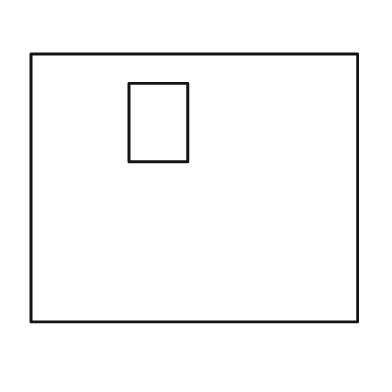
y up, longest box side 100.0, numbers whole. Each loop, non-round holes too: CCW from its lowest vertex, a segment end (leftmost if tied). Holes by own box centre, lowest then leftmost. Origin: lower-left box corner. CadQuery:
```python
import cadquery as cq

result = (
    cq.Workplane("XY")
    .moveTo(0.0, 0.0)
    .lineTo(100.0, 0.0)
    .lineTo(100.0, 82.0)
    .lineTo(0.0, 82.0)
    .close()
    .moveTo(30.0, 49.0)
    .lineTo(48.0, 49.0)
    .lineTo(48.0, 73.0)
    .lineTo(30.0, 73.0)
    .close()
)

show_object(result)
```